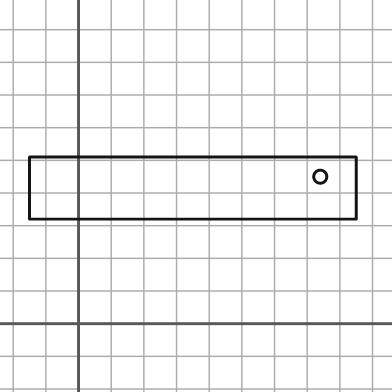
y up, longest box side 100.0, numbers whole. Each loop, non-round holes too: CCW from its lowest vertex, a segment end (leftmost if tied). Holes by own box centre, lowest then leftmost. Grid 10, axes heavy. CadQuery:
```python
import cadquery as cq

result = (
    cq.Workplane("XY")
    .moveTo(-15.0, 32.0)
    .lineTo(85.0, 32.0)
    .lineTo(85.0, 51.0)
    .lineTo(-15.0, 51.0)
    .close()
    .moveTo(74.0, 45.0)
    .circle(2.0)
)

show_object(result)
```